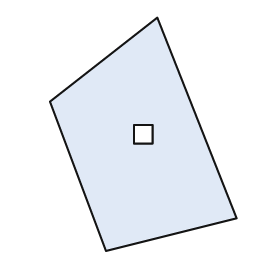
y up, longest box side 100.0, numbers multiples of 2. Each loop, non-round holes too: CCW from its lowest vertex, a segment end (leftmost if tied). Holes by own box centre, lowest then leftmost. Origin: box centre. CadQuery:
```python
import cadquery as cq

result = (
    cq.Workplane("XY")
    .moveTo(-16.0, -50.0)
    .lineTo(40.0, -36.0)
    .lineTo(6.0, 50.0)
    .lineTo(-40.0, 14.0)
    .close()
    .moveTo(-4.0, -4.0)
    .lineTo(4.0, -4.0)
    .lineTo(4.0, 4.0)
    .lineTo(-4.0, 4.0)
    .close()
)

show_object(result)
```